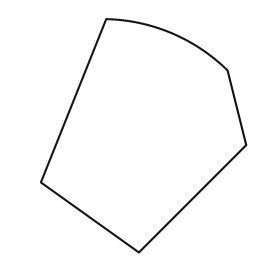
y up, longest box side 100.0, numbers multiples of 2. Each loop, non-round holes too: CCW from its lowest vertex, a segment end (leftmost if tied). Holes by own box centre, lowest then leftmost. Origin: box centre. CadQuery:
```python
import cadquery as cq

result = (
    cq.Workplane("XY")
    .moveTo(-2.0, -50.0)
    .lineTo(44.0, -4.0)
    .lineTo(36.0, 28.0)
    .threePointArc((12.0, 44.0), (-16.0, 50.0))
    .lineTo(-44.0, -20.0)
    .close()
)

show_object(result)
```